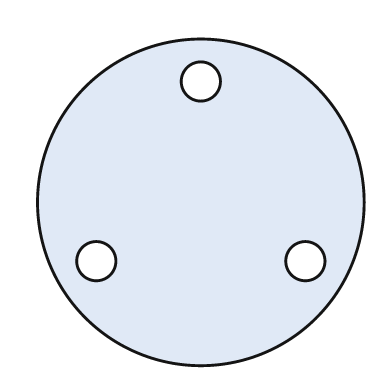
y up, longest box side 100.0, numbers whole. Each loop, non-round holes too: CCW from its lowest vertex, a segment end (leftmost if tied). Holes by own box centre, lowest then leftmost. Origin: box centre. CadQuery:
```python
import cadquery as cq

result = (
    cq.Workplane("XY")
    .moveTo(0.0, 0.0)
    .circle(50.0)
    .moveTo(-32.0, -18.0)
    .circle(6.0)
    .moveTo(32.0, -18.0)
    .circle(6.0)
    .moveTo(0.0, 37.0)
    .circle(6.0)
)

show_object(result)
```